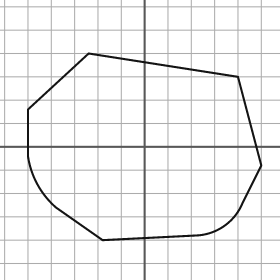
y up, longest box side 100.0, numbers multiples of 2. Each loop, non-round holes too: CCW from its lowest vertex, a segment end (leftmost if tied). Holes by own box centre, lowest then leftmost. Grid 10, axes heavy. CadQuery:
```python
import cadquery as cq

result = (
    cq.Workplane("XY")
    .moveTo(-18.0, -40.0)
    .lineTo(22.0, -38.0)
    .threePointArc((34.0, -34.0), (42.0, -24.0))
    .lineTo(50.0, -8.0)
    .lineTo(40.0, 30.0)
    .lineTo(-24.0, 40.0)
    .lineTo(-50.0, 16.0)
    .lineTo(-50.0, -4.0)
    .threePointArc((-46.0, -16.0), (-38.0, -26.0))
    .close()
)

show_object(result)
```